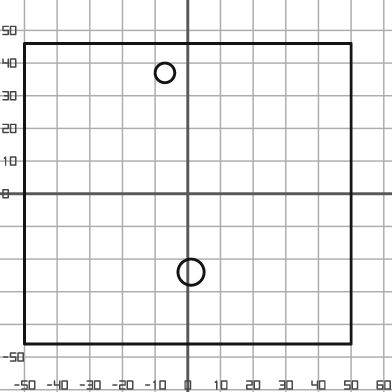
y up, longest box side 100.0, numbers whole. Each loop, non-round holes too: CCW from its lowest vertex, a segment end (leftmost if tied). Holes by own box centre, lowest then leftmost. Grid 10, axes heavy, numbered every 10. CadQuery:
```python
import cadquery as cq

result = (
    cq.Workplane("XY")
    .moveTo(-50.0, -46.0)
    .lineTo(50.0, -46.0)
    .lineTo(50.0, 46.0)
    .lineTo(-50.0, 46.0)
    .close()
    .moveTo(1.0, -24.0)
    .circle(4.0)
    .moveTo(-7.0, 37.0)
    .circle(3.0)
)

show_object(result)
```